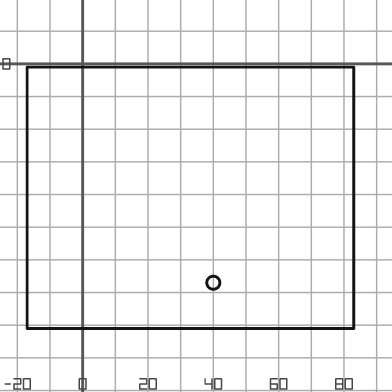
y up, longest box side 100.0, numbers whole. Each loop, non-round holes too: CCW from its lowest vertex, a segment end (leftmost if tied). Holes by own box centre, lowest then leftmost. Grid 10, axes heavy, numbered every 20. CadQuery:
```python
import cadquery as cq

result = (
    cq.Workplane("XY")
    .moveTo(-17.0, -81.0)
    .lineTo(83.0, -81.0)
    .lineTo(83.0, -1.0)
    .lineTo(-17.0, -1.0)
    .close()
    .moveTo(40.0, -67.0)
    .circle(2.0)
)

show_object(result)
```